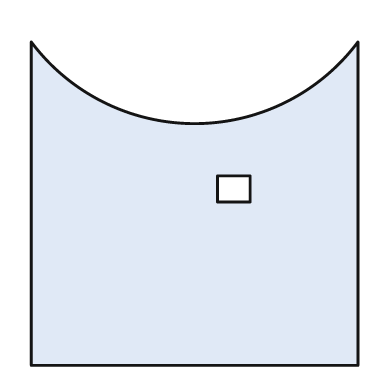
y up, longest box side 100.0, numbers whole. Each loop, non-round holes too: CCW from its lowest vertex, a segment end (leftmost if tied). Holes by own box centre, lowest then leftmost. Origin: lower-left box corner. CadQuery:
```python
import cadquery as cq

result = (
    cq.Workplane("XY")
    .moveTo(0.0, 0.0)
    .lineTo(100.0, 0.0)
    .lineTo(100.0, 99.0)
    .threePointArc((50.0, 74.0), (0.0, 99.0))
    .close()
    .moveTo(57.0, 50.0)
    .lineTo(67.0, 50.0)
    .lineTo(67.0, 58.0)
    .lineTo(57.0, 58.0)
    .close()
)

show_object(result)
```